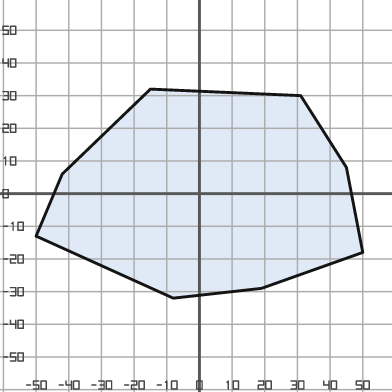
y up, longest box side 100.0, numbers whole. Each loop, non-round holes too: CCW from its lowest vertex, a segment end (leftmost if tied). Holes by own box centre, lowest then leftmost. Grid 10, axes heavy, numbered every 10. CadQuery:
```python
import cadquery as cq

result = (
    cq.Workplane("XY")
    .moveTo(-8.0, -32.0)
    .lineTo(19.0, -29.0)
    .lineTo(50.0, -18.0)
    .lineTo(45.0, 8.0)
    .lineTo(31.0, 30.0)
    .lineTo(-15.0, 32.0)
    .lineTo(-42.0, 6.0)
    .lineTo(-50.0, -13.0)
    .close()
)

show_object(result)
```